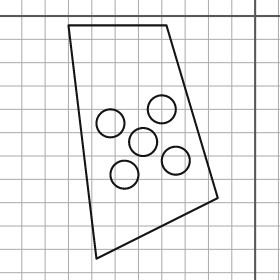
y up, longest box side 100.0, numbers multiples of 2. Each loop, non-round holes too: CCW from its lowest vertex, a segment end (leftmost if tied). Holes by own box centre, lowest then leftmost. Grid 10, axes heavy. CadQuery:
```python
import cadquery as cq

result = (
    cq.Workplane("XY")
    .moveTo(-68.0, -104.0)
    .lineTo(-16.0, -78.0)
    .lineTo(-38.0, -4.0)
    .lineTo(-80.0, -4.0)
    .close()
    .moveTo(-56.0, -68.0)
    .circle(6.0)
    .moveTo(-34.0, -62.0)
    .circle(6.0)
    .moveTo(-48.0, -54.0)
    .circle(6.0)
    .moveTo(-62.0, -46.0)
    .circle(6.0)
    .moveTo(-40.0, -40.0)
    .circle(6.0)
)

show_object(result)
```